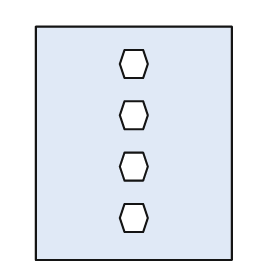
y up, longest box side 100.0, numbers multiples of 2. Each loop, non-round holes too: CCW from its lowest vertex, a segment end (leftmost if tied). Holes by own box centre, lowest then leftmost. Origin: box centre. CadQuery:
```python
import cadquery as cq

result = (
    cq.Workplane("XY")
    .moveTo(-42.0, -50.0)
    .lineTo(42.0, -50.0)
    .lineTo(42.0, 50.0)
    .lineTo(-42.0, 50.0)
    .close()
    .moveTo(-4.0, -38.0)
    .lineTo(4.0, -38.0)
    .lineTo(6.0, -32.0)
    .lineTo(4.0, -26.0)
    .lineTo(-4.0, -26.0)
    .lineTo(-6.0, -32.0)
    .close()
    .moveTo(-4.0, -16.0)
    .lineTo(4.0, -16.0)
    .lineTo(6.0, -10.0)
    .lineTo(4.0, -4.0)
    .lineTo(-4.0, -4.0)
    .lineTo(-6.0, -10.0)
    .close()
    .moveTo(-4.0, 6.0)
    .lineTo(4.0, 6.0)
    .lineTo(6.0, 12.0)
    .lineTo(4.0, 18.0)
    .lineTo(-4.0, 18.0)
    .lineTo(-6.0, 12.0)
    .close()
    .moveTo(-4.0, 28.0)
    .lineTo(4.0, 28.0)
    .lineTo(6.0, 34.0)
    .lineTo(4.0, 40.0)
    .lineTo(-4.0, 40.0)
    .lineTo(-6.0, 34.0)
    .close()
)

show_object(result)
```